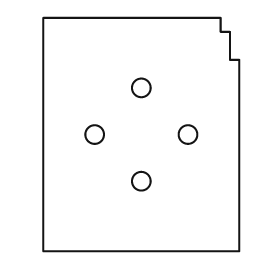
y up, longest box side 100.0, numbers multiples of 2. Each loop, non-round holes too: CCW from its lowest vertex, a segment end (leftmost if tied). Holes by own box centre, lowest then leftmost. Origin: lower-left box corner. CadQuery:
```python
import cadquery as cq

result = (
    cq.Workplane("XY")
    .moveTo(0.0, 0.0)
    .lineTo(84.0, 0.0)
    .lineTo(84.0, 82.0)
    .lineTo(80.0, 82.0)
    .lineTo(80.0, 94.0)
    .lineTo(76.0, 94.0)
    .lineTo(76.0, 100.0)
    .lineTo(0.0, 100.0)
    .close()
    .moveTo(42.0, 30.0)
    .circle(4.0)
    .moveTo(22.0, 50.0)
    .circle(4.0)
    .moveTo(62.0, 50.0)
    .circle(4.0)
    .moveTo(42.0, 70.0)
    .circle(4.0)
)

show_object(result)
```